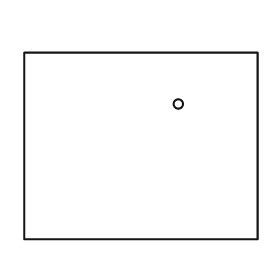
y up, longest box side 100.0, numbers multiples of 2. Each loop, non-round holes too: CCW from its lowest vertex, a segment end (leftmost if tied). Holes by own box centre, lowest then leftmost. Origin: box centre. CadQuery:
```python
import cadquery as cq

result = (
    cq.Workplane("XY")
    .moveTo(-50.0, -40.0)
    .lineTo(50.0, -40.0)
    .lineTo(50.0, 40.0)
    .lineTo(-50.0, 40.0)
    .close()
    .moveTo(16.0, 18.0)
    .circle(2.0)
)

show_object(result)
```